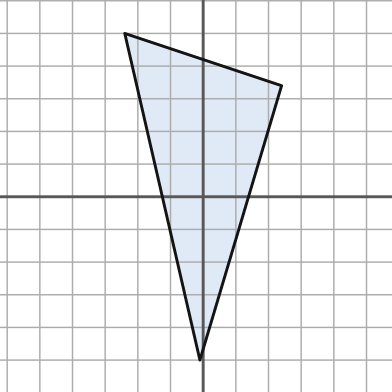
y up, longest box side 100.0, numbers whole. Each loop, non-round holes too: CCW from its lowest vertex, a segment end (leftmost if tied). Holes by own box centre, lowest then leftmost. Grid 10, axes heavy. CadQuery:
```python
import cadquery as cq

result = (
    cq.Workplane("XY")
    .moveTo(-1.0, -50.0)
    .lineTo(24.0, 34.0)
    .lineTo(-24.0, 50.0)
    .close()
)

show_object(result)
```